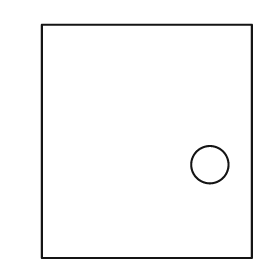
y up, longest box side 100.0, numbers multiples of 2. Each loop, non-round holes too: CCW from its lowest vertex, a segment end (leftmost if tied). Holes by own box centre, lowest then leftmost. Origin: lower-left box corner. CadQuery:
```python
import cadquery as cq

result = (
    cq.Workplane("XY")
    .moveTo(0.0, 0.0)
    .lineTo(90.0, 0.0)
    .lineTo(90.0, 100.0)
    .lineTo(0.0, 100.0)
    .close()
    .moveTo(72.0, 40.0)
    .circle(8.0)
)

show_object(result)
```